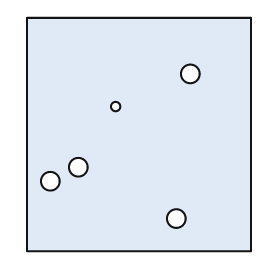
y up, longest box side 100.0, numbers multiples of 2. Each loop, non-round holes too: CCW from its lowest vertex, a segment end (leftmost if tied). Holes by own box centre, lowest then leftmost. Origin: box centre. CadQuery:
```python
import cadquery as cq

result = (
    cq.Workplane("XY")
    .moveTo(-48.0, -50.0)
    .lineTo(48.0, -50.0)
    .lineTo(48.0, 50.0)
    .lineTo(-48.0, 50.0)
    .close()
    .moveTo(16.0, -36.0)
    .circle(4.0)
    .moveTo(-38.0, -20.0)
    .circle(4.0)
    .moveTo(-26.0, -14.0)
    .circle(4.0)
    .moveTo(-10.0, 12.0)
    .circle(2.0)
    .moveTo(22.0, 26.0)
    .circle(4.0)
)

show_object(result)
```